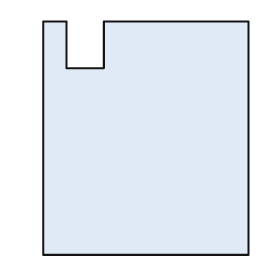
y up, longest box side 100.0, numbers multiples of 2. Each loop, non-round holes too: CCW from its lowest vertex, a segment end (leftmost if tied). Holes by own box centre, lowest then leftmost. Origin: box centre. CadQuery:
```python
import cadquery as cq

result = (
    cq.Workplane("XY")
    .moveTo(-44.0, -50.0)
    .lineTo(44.0, -50.0)
    .lineTo(44.0, 50.0)
    .lineTo(-18.0, 50.0)
    .lineTo(-18.0, 30.0)
    .lineTo(-34.0, 30.0)
    .lineTo(-34.0, 50.0)
    .lineTo(-44.0, 50.0)
    .close()
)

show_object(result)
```